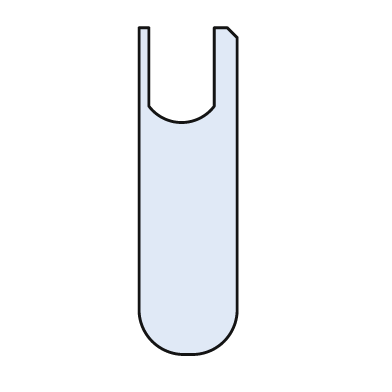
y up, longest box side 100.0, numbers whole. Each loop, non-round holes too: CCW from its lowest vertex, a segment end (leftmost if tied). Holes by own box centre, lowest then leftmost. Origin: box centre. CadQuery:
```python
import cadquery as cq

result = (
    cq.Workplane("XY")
    .moveTo(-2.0, -50.0)
    .lineTo(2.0, -50.0)
    .threePointArc((11.0, -46.0), (15.0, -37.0))
    .lineTo(15.0, 47.0)
    .lineTo(12.0, 50.0)
    .lineTo(8.0, 50.0)
    .lineTo(8.0, 26.0)
    .threePointArc((-2.0, 21.0), (-12.0, 26.0))
    .lineTo(-12.0, 50.0)
    .lineTo(-15.0, 50.0)
    .lineTo(-15.0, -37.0)
    .threePointArc((-11.0, -46.0), (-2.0, -50.0))
    .close()
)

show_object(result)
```